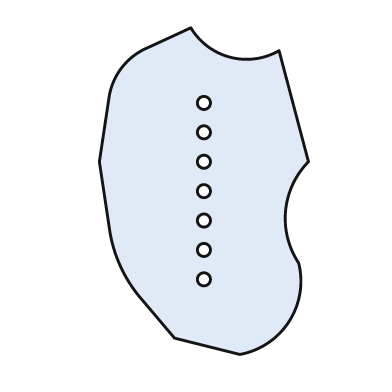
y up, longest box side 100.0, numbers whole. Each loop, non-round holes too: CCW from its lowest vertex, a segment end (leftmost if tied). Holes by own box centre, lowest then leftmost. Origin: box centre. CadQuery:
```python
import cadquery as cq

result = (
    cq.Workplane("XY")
    .moveTo(11.0, -50.0)
    .threePointArc((26.0, -40.0), (29.0, -22.0))
    .threePointArc((25.0, -6.0), (32.0, 9.0))
    .lineTo(23.0, 43.0)
    .threePointArc((8.0, 41.0), (-4.0, 50.0))
    .lineTo(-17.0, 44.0)
    .threePointArc((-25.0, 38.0), (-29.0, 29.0))
    .lineTo(-32.0, 9.0)
    .lineTo(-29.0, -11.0)
    .threePointArc((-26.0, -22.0), (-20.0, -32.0))
    .lineTo(-9.0, -45.0)
    .close()
    .moveTo(0.0, -27.0)
    .circle(2.0)
    .moveTo(0.0, -18.0)
    .circle(2.0)
    .moveTo(0.0, -9.0)
    .circle(2.0)
    .moveTo(0.0, 0.0)
    .circle(2.0)
    .moveTo(0.0, 9.0)
    .circle(2.0)
    .moveTo(0.0, 18.0)
    .circle(2.0)
    .moveTo(0.0, 27.0)
    .circle(2.0)
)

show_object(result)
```